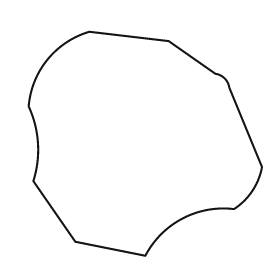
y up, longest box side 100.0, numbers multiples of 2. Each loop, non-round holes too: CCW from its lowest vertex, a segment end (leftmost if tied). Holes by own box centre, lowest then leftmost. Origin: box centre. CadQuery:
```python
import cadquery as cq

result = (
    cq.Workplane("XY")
    .moveTo(0.0, -48.0)
    .threePointArc((16.0, -32.0), (38.0, -28.0))
    .threePointArc((46.0, -20.0), (50.0, -10.0))
    .lineTo(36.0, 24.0)
    .threePointArc((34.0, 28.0), (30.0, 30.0))
    .lineTo(10.0, 44.0)
    .lineTo(-24.0, 48.0)
    .threePointArc((-42.0, 36.0), (-50.0, 16.0))
    .threePointArc((-46.0, 0.0), (-48.0, -16.0))
    .lineTo(-30.0, -42.0)
    .close()
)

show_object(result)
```